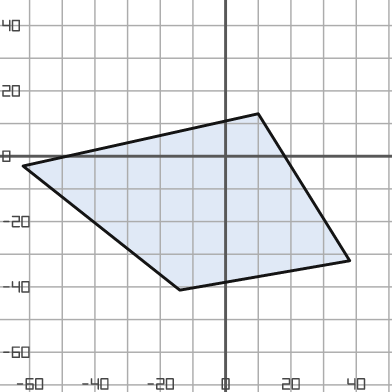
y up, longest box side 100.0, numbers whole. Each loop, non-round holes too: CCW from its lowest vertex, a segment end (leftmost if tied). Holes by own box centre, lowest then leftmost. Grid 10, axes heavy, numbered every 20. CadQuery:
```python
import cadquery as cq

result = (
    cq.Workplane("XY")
    .moveTo(-14.0, -41.0)
    .lineTo(38.0, -32.0)
    .lineTo(10.0, 13.0)
    .lineTo(-62.0, -3.0)
    .close()
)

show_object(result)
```